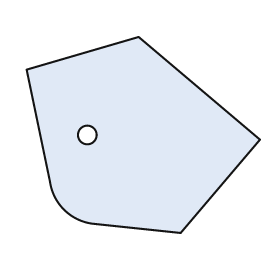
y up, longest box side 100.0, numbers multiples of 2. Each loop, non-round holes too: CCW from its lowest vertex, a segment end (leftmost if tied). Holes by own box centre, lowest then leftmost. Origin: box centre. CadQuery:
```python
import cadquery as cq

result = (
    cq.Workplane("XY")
    .moveTo(16.0, -42.0)
    .lineTo(50.0, -2.0)
    .lineTo(-2.0, 42.0)
    .lineTo(-50.0, 28.0)
    .lineTo(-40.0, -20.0)
    .threePointArc((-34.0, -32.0), (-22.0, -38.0))
    .close()
    .moveTo(-24.0, 0.0)
    .circle(4.0)
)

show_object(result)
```